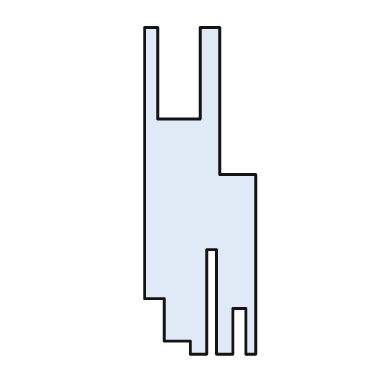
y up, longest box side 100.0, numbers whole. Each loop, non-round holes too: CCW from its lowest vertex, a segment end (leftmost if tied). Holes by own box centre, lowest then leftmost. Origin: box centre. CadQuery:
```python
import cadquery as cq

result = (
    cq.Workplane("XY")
    .moveTo(-3.0, -50.0)
    .lineTo(2.0, -50.0)
    .lineTo(2.0, -18.0)
    .lineTo(5.0, -18.0)
    .lineTo(5.0, -50.0)
    .lineTo(10.0, -50.0)
    .lineTo(10.0, -36.0)
    .lineTo(14.0, -36.0)
    .lineTo(14.0, -50.0)
    .lineTo(17.0, -50.0)
    .lineTo(17.0, 5.0)
    .lineTo(6.0, 5.0)
    .lineTo(6.0, 50.0)
    .lineTo(0.0, 50.0)
    .lineTo(0.0, 22.0)
    .lineTo(-13.0, 22.0)
    .lineTo(-13.0, 50.0)
    .lineTo(-17.0, 50.0)
    .lineTo(-17.0, -33.0)
    .lineTo(-11.0, -33.0)
    .lineTo(-11.0, -46.0)
    .lineTo(-3.0, -46.0)
    .close()
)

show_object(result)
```